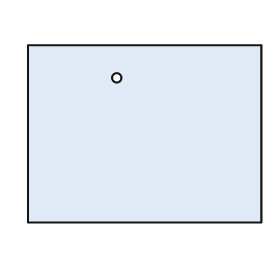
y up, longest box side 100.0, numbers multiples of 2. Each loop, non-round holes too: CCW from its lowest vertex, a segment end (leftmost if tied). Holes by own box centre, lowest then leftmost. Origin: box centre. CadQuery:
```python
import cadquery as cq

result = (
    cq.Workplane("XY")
    .moveTo(-50.0, -38.0)
    .lineTo(50.0, -38.0)
    .lineTo(50.0, 38.0)
    .lineTo(-50.0, 38.0)
    .close()
    .moveTo(-12.0, 24.0)
    .circle(2.0)
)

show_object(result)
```